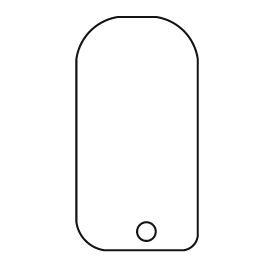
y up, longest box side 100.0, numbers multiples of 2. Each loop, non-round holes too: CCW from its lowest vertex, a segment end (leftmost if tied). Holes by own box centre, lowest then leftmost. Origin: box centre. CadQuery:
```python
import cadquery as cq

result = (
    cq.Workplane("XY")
    .moveTo(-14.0, -50.0)
    .lineTo(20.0, -50.0)
    .threePointArc((24.0, -48.0), (26.0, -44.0))
    .lineTo(26.0, 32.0)
    .threePointArc((20.0, 44.0), (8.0, 50.0))
    .lineTo(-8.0, 50.0)
    .threePointArc((-20.0, 44.0), (-26.0, 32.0))
    .lineTo(-26.0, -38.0)
    .threePointArc((-22.0, -46.0), (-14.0, -50.0))
    .close()
    .moveTo(4.0, -42.0)
    .circle(4.0)
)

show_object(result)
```